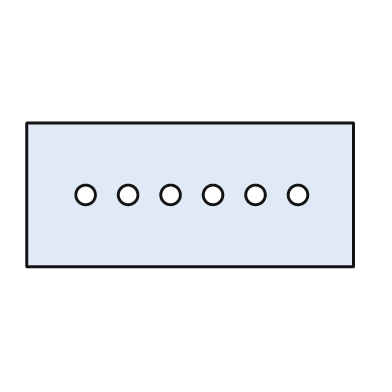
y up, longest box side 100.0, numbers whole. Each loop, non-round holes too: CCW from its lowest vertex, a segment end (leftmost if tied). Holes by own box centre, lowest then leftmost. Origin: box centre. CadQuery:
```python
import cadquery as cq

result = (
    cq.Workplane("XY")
    .moveTo(-50.0, -22.0)
    .lineTo(50.0, -22.0)
    .lineTo(50.0, 22.0)
    .lineTo(-50.0, 22.0)
    .close()
    .moveTo(-32.0, 0.0)
    .circle(3.0)
    .moveTo(-19.0, 0.0)
    .circle(3.0)
    .moveTo(-6.0, 0.0)
    .circle(3.0)
    .moveTo(7.0, 0.0)
    .circle(3.0)
    .moveTo(20.0, 0.0)
    .circle(3.0)
    .moveTo(33.0, 0.0)
    .circle(3.0)
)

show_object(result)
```